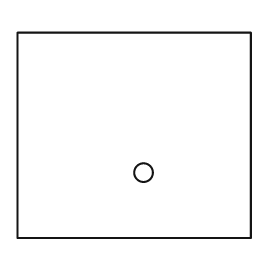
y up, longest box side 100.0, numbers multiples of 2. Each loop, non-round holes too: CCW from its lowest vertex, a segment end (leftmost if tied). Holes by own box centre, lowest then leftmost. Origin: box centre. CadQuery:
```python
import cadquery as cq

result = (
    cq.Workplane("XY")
    .moveTo(-50.0, -44.0)
    .lineTo(50.0, -44.0)
    .lineTo(50.0, 44.0)
    .lineTo(-50.0, 44.0)
    .close()
    .moveTo(4.0, -16.0)
    .circle(4.0)
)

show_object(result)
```